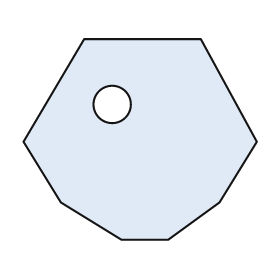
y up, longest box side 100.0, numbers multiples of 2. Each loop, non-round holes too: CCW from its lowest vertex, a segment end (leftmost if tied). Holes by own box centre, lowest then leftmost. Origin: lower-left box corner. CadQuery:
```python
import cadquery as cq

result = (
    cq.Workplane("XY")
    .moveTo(42.0, 0.0)
    .lineTo(62.0, 0.0)
    .lineTo(84.0, 16.0)
    .lineTo(100.0, 42.0)
    .lineTo(76.0, 86.0)
    .lineTo(26.0, 86.0)
    .lineTo(0.0, 42.0)
    .lineTo(16.0, 16.0)
    .close()
    .moveTo(38.0, 58.0)
    .circle(8.0)
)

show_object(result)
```